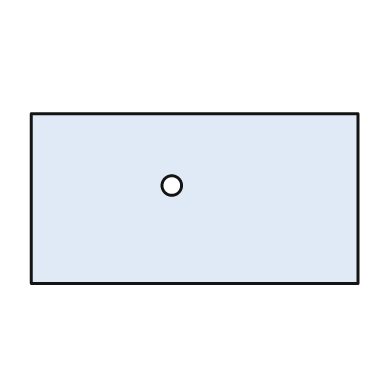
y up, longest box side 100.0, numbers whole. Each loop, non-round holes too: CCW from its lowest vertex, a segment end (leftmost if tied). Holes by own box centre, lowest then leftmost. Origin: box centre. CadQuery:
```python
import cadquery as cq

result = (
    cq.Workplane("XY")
    .moveTo(-50.0, -26.0)
    .lineTo(50.0, -26.0)
    .lineTo(50.0, 26.0)
    .lineTo(-50.0, 26.0)
    .close()
    .moveTo(-7.0, 4.0)
    .circle(3.0)
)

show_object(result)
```